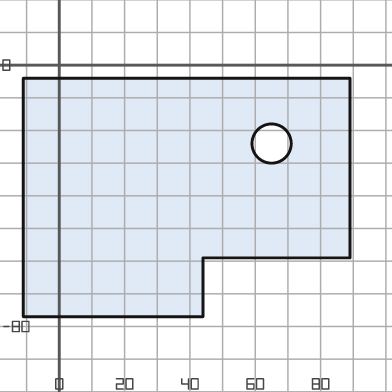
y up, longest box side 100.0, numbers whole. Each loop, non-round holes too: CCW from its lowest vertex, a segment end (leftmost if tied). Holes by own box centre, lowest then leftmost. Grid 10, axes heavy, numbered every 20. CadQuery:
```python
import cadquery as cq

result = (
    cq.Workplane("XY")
    .moveTo(-11.0, -77.0)
    .lineTo(44.0, -77.0)
    .lineTo(44.0, -59.0)
    .lineTo(89.0, -59.0)
    .lineTo(89.0, -4.0)
    .lineTo(-11.0, -4.0)
    .close()
    .moveTo(65.0, -24.0)
    .circle(6.0)
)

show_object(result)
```